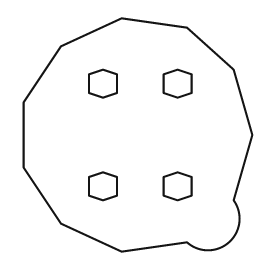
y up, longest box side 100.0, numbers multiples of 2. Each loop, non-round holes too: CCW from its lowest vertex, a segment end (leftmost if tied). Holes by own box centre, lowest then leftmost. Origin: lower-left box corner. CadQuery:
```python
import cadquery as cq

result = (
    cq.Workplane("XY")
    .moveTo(42.0, 0.0)
    .lineTo(70.0, 4.0)
    .threePointArc((88.0, 4.0), (90.0, 22.0))
    .lineTo(98.0, 50.0)
    .lineTo(90.0, 78.0)
    .lineTo(70.0, 96.0)
    .lineTo(42.0, 100.0)
    .lineTo(16.0, 88.0)
    .lineTo(0.0, 64.0)
    .lineTo(0.0, 36.0)
    .lineTo(16.0, 12.0)
    .close()
    .moveTo(34.0, 22.0)
    .lineTo(40.0, 24.0)
    .lineTo(40.0, 32.0)
    .lineTo(34.0, 34.0)
    .lineTo(28.0, 32.0)
    .lineTo(28.0, 24.0)
    .close()
    .moveTo(66.0, 22.0)
    .lineTo(72.0, 24.0)
    .lineTo(72.0, 32.0)
    .lineTo(66.0, 34.0)
    .lineTo(60.0, 32.0)
    .lineTo(60.0, 24.0)
    .close()
    .moveTo(34.0, 66.0)
    .lineTo(40.0, 68.0)
    .lineTo(40.0, 76.0)
    .lineTo(34.0, 78.0)
    .lineTo(28.0, 76.0)
    .lineTo(28.0, 68.0)
    .close()
    .moveTo(66.0, 66.0)
    .lineTo(72.0, 68.0)
    .lineTo(72.0, 76.0)
    .lineTo(66.0, 78.0)
    .lineTo(60.0, 76.0)
    .lineTo(60.0, 68.0)
    .close()
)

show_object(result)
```